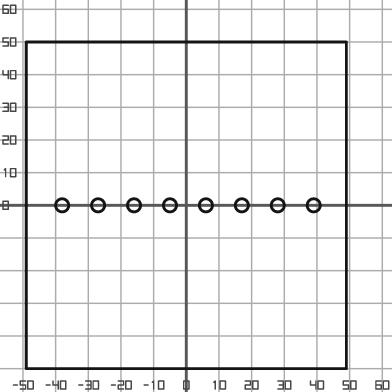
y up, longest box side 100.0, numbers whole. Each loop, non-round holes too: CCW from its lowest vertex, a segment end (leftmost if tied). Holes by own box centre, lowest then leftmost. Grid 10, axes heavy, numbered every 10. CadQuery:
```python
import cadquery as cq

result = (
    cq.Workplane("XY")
    .moveTo(-49.0, -50.0)
    .lineTo(49.0, -50.0)
    .lineTo(49.0, 50.0)
    .lineTo(-49.0, 50.0)
    .close()
    .moveTo(-38.0, 0.0)
    .circle(2.0)
    .moveTo(-27.0, 0.0)
    .circle(2.0)
    .moveTo(-16.0, 0.0)
    .circle(2.0)
    .moveTo(-5.0, 0.0)
    .circle(2.0)
    .moveTo(6.0, 0.0)
    .circle(2.0)
    .moveTo(17.0, 0.0)
    .circle(2.0)
    .moveTo(28.0, 0.0)
    .circle(2.0)
    .moveTo(39.0, 0.0)
    .circle(2.0)
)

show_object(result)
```